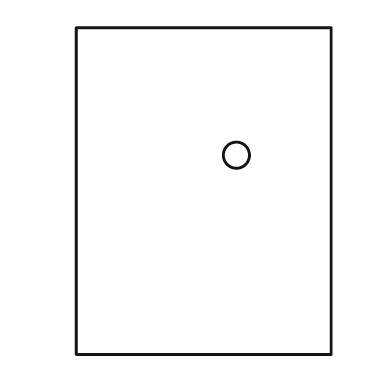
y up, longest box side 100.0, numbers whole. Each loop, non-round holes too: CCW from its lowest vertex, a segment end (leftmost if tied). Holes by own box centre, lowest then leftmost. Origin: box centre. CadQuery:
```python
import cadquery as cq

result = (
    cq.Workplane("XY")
    .moveTo(-39.0, -50.0)
    .lineTo(39.0, -50.0)
    .lineTo(39.0, 50.0)
    .lineTo(-39.0, 50.0)
    .close()
    .moveTo(10.0, 11.0)
    .circle(4.0)
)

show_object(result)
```